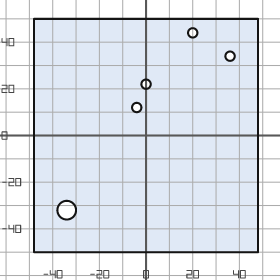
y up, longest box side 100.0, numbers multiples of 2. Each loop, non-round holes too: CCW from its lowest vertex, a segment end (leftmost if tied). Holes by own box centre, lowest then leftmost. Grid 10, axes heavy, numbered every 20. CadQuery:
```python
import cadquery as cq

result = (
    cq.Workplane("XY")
    .moveTo(-48.0, -50.0)
    .lineTo(48.0, -50.0)
    .lineTo(48.0, 50.0)
    .lineTo(-48.0, 50.0)
    .close()
    .moveTo(-34.0, -32.0)
    .circle(4.0)
    .moveTo(-4.0, 12.0)
    .circle(2.0)
    .moveTo(0.0, 22.0)
    .circle(2.0)
    .moveTo(36.0, 34.0)
    .circle(2.0)
    .moveTo(20.0, 44.0)
    .circle(2.0)
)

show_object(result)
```